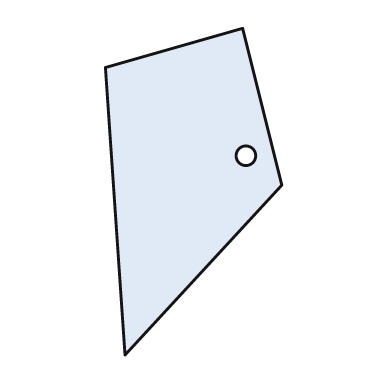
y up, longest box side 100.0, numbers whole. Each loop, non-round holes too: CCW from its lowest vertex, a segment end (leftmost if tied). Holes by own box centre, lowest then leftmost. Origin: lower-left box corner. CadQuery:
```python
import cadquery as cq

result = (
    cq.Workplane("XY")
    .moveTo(6.0, 0.0)
    .lineTo(54.0, 52.0)
    .lineTo(42.0, 100.0)
    .lineTo(0.0, 88.0)
    .close()
    .moveTo(43.0, 61.0)
    .circle(3.0)
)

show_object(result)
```